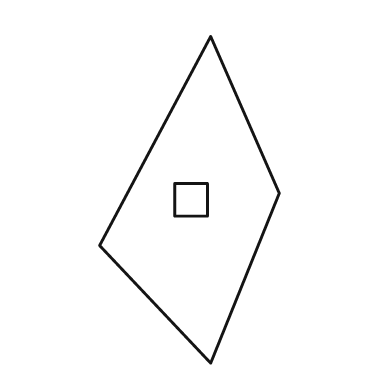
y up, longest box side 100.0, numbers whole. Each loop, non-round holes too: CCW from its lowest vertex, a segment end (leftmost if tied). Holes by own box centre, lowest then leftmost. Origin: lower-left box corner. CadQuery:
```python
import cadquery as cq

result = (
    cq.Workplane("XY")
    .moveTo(34.0, 0.0)
    .lineTo(55.0, 52.0)
    .lineTo(34.0, 100.0)
    .lineTo(0.0, 36.0)
    .close()
    .moveTo(23.0, 45.0)
    .lineTo(33.0, 45.0)
    .lineTo(33.0, 55.0)
    .lineTo(23.0, 55.0)
    .close()
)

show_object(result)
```